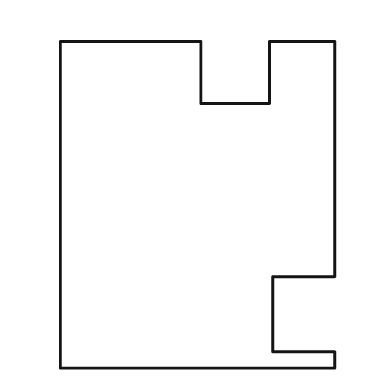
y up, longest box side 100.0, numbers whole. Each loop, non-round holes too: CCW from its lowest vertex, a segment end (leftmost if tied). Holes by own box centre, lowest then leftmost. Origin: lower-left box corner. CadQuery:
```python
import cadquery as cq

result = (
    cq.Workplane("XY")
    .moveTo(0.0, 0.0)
    .lineTo(84.0, 0.0)
    .lineTo(84.0, 5.0)
    .lineTo(65.0, 5.0)
    .lineTo(65.0, 28.0)
    .lineTo(84.0, 28.0)
    .lineTo(84.0, 100.0)
    .lineTo(64.0, 100.0)
    .lineTo(64.0, 81.0)
    .lineTo(43.0, 81.0)
    .lineTo(43.0, 100.0)
    .lineTo(0.0, 100.0)
    .close()
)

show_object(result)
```